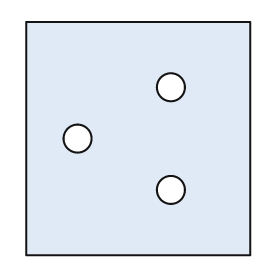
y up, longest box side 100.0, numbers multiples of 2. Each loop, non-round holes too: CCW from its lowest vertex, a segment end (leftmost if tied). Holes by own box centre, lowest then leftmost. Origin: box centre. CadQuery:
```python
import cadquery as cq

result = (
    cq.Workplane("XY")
    .moveTo(-48.0, -50.0)
    .lineTo(48.0, -50.0)
    .lineTo(48.0, 50.0)
    .lineTo(-48.0, 50.0)
    .close()
    .moveTo(14.0, -22.0)
    .circle(6.0)
    .moveTo(-26.0, 0.0)
    .circle(6.0)
    .moveTo(14.0, 22.0)
    .circle(6.0)
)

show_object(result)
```